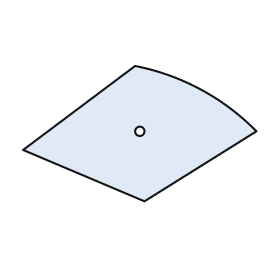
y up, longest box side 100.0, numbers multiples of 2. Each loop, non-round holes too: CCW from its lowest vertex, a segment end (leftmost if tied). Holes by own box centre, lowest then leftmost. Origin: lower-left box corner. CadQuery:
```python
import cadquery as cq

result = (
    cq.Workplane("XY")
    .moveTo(52.0, 0.0)
    .lineTo(100.0, 30.0)
    .threePointArc((76.0, 48.0), (48.0, 58.0))
    .lineTo(0.0, 22.0)
    .close()
    .moveTo(50.0, 30.0)
    .circle(2.0)
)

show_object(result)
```